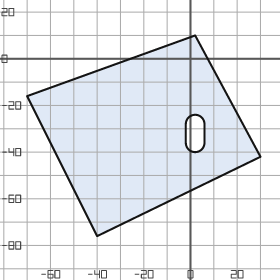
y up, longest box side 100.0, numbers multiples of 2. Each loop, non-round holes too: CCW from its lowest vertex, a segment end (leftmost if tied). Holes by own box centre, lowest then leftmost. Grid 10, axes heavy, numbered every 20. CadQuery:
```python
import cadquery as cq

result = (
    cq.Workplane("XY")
    .moveTo(-40.0, -76.0)
    .lineTo(30.0, -42.0)
    .lineTo(2.0, 10.0)
    .lineTo(-70.0, -16.0)
    .close()
    .moveTo(-2.0, -36.0)
    .threePointArc((2.0, -40.0), (6.0, -36.0))
    .lineTo(6.0, -28.0)
    .threePointArc((2.0, -24.0), (-2.0, -28.0))
    .close()
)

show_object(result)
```